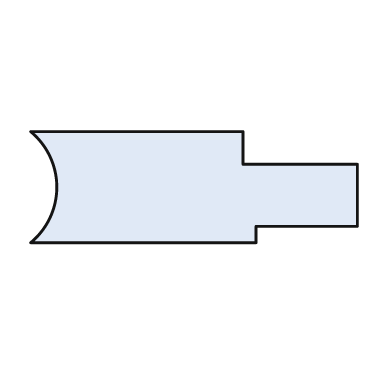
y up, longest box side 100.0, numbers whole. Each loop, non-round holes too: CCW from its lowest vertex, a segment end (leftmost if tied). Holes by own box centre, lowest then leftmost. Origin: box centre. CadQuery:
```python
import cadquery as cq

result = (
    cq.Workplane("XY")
    .moveTo(-50.0, -17.0)
    .lineTo(19.0, -17.0)
    .lineTo(19.0, -12.0)
    .lineTo(50.0, -12.0)
    .lineTo(50.0, 7.0)
    .lineTo(15.0, 7.0)
    .lineTo(15.0, 17.0)
    .lineTo(-50.0, 17.0)
    .threePointArc((-42.0, 0.0), (-50.0, -17.0))
    .close()
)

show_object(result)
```